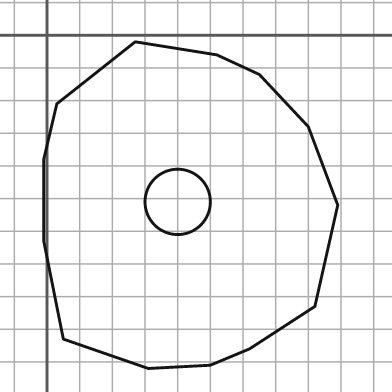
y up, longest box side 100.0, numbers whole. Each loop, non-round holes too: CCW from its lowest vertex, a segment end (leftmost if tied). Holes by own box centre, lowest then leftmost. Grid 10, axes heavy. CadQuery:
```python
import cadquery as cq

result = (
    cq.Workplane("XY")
    .moveTo(31.0, -102.0)
    .lineTo(50.0, -101.0)
    .lineTo(62.0, -96.0)
    .lineTo(82.0, -83.0)
    .lineTo(89.0, -52.0)
    .lineTo(80.0, -28.0)
    .lineTo(65.0, -12.0)
    .lineTo(52.0, -6.0)
    .lineTo(27.0, -2.0)
    .lineTo(3.0, -21.0)
    .lineTo(-1.0, -38.0)
    .lineTo(-1.0, -63.0)
    .lineTo(5.0, -93.0)
    .close()
    .moveTo(40.0, -51.0)
    .circle(10.0)
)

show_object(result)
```